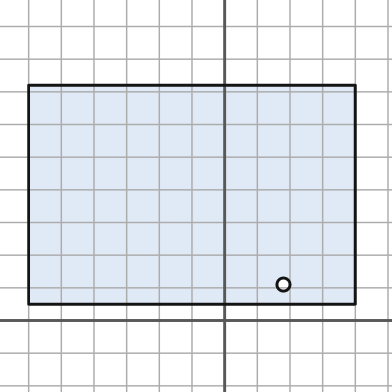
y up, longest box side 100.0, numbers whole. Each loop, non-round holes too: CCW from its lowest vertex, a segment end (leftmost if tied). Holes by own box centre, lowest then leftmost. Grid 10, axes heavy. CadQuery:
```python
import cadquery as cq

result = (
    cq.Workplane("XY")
    .moveTo(-60.0, 5.0)
    .lineTo(40.0, 5.0)
    .lineTo(40.0, 72.0)
    .lineTo(-60.0, 72.0)
    .close()
    .moveTo(18.0, 11.0)
    .circle(2.0)
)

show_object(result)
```